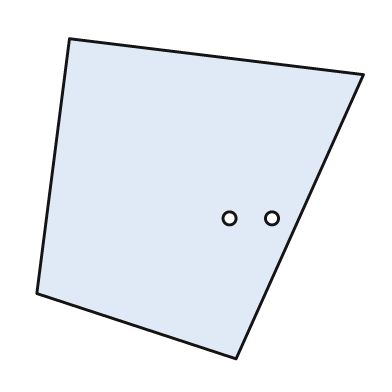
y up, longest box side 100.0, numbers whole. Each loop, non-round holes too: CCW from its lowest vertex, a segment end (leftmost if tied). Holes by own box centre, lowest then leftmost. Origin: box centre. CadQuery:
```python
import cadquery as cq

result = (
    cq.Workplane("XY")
    .moveTo(11.0, -49.0)
    .lineTo(50.0, 38.0)
    .lineTo(-40.0, 49.0)
    .lineTo(-50.0, -29.0)
    .close()
    .moveTo(9.0, -6.0)
    .circle(2.0)
    .moveTo(22.0, -6.0)
    .circle(2.0)
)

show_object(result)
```